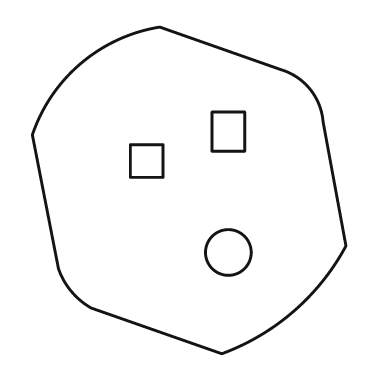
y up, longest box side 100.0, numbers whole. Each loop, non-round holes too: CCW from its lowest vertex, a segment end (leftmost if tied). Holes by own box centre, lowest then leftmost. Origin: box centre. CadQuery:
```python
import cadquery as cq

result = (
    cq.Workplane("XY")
    .moveTo(10.0, -50.0)
    .threePointArc((32.0, -37.0), (48.0, -17.0))
    .lineTo(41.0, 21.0)
    .threePointArc((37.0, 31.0), (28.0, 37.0))
    .lineTo(-9.0, 50.0)
    .threePointArc((-33.0, 39.0), (-48.0, 17.0))
    .lineTo(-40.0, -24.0)
    .threePointArc((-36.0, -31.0), (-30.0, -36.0))
    .close()
    .moveTo(12.0, -19.0)
    .circle(7.0)
    .moveTo(-18.0, 4.0)
    .lineTo(-8.0, 4.0)
    .lineTo(-8.0, 14.0)
    .lineTo(-18.0, 14.0)
    .close()
    .moveTo(7.0, 12.0)
    .lineTo(17.0, 12.0)
    .lineTo(17.0, 24.0)
    .lineTo(7.0, 24.0)
    .close()
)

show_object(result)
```